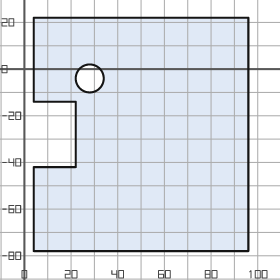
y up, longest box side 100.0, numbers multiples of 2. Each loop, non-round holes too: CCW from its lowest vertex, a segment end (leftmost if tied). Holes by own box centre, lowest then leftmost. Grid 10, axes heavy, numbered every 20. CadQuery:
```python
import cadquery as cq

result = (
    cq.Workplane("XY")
    .moveTo(4.0, -78.0)
    .lineTo(96.0, -78.0)
    .lineTo(96.0, 22.0)
    .lineTo(4.0, 22.0)
    .lineTo(4.0, -14.0)
    .lineTo(22.0, -14.0)
    .lineTo(22.0, -42.0)
    .lineTo(4.0, -42.0)
    .close()
    .moveTo(28.0, -4.0)
    .circle(6.0)
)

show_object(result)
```